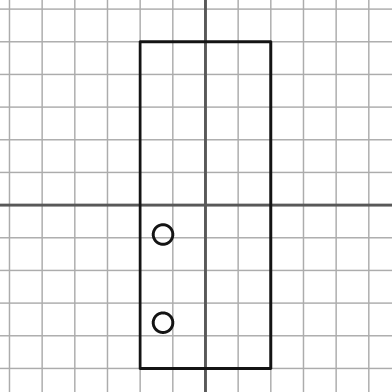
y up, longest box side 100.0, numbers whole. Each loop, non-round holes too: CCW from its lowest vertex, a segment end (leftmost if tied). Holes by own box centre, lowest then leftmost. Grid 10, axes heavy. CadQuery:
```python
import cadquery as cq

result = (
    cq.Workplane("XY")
    .moveTo(-20.0, -50.0)
    .lineTo(20.0, -50.0)
    .lineTo(20.0, 50.0)
    .lineTo(-20.0, 50.0)
    .close()
    .moveTo(-13.0, -36.0)
    .circle(3.0)
    .moveTo(-13.0, -9.0)
    .circle(3.0)
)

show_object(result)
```